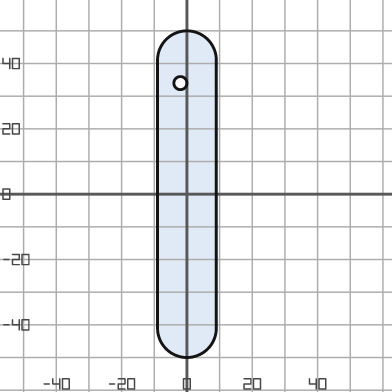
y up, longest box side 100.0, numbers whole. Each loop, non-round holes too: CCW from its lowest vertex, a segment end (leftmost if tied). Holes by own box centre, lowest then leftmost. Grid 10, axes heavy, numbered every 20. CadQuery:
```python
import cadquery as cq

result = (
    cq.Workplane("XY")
    .moveTo(-9.0, -41.0)
    .threePointArc((0.0, -50.0), (9.0, -41.0))
    .lineTo(9.0, 41.0)
    .threePointArc((0.0, 50.0), (-9.0, 41.0))
    .close()
    .moveTo(-2.0, 34.0)
    .circle(2.0)
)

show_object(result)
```